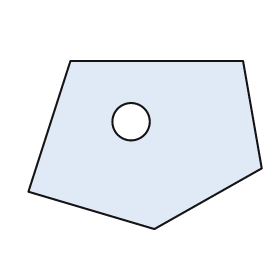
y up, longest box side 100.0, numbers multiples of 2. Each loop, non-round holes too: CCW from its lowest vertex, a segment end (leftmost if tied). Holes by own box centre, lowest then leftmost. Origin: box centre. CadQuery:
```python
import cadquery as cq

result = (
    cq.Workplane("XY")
    .moveTo(4.0, -36.0)
    .lineTo(50.0, -10.0)
    .lineTo(42.0, 36.0)
    .lineTo(-32.0, 36.0)
    .lineTo(-50.0, -20.0)
    .close()
    .moveTo(-6.0, 10.0)
    .circle(8.0)
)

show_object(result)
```